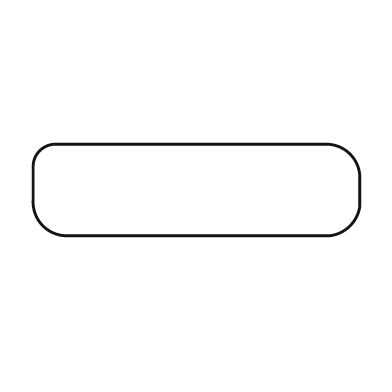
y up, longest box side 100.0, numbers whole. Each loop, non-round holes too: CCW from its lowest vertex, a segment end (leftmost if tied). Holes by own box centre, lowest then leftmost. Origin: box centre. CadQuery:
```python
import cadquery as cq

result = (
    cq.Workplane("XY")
    .moveTo(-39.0, -14.0)
    .lineTo(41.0, -14.0)
    .threePointArc((47.0, -11.0), (50.0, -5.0))
    .lineTo(50.0, 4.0)
    .threePointArc((47.0, 11.0), (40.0, 14.0))
    .lineTo(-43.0, 14.0)
    .threePointArc((-48.0, 12.0), (-50.0, 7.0))
    .lineTo(-50.0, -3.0)
    .threePointArc((-47.0, -11.0), (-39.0, -14.0))
    .close()
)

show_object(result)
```